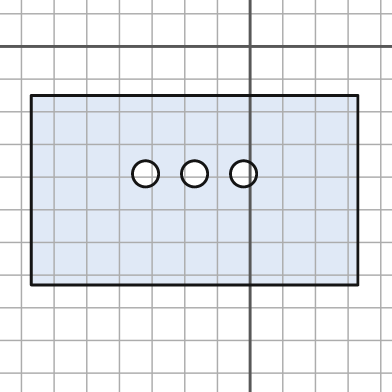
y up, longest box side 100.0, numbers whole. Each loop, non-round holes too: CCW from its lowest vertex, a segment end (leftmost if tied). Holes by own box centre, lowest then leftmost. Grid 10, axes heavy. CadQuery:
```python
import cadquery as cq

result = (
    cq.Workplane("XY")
    .moveTo(-67.0, -73.0)
    .lineTo(33.0, -73.0)
    .lineTo(33.0, -15.0)
    .lineTo(-67.0, -15.0)
    .close()
    .moveTo(-32.0, -39.0)
    .circle(4.0)
    .moveTo(-17.0, -39.0)
    .circle(4.0)
    .moveTo(-2.0, -39.0)
    .circle(4.0)
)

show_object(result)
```